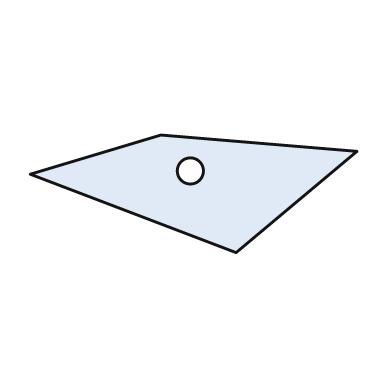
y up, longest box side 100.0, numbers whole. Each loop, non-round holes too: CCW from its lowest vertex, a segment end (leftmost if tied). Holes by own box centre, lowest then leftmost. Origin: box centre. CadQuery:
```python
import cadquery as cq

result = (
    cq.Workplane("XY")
    .moveTo(13.0, -18.0)
    .lineTo(50.0, 13.0)
    .lineTo(-10.0, 18.0)
    .lineTo(-50.0, 6.0)
    .close()
    .moveTo(-1.0, 7.0)
    .circle(4.0)
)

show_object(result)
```